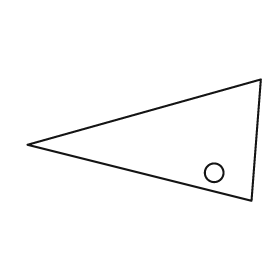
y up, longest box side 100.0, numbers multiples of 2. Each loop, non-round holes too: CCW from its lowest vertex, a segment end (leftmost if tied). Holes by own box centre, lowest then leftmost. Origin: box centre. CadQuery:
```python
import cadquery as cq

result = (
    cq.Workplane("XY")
    .moveTo(46.0, -26.0)
    .lineTo(50.0, 26.0)
    .lineTo(-50.0, -2.0)
    .close()
    .moveTo(30.0, -14.0)
    .circle(4.0)
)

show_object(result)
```